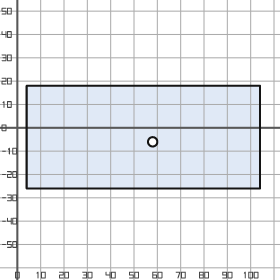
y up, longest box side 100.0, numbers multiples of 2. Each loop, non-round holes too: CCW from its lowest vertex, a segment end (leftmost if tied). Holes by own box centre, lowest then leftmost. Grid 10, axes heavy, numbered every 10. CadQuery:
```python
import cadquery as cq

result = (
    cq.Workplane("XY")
    .moveTo(4.0, -26.0)
    .lineTo(104.0, -26.0)
    .lineTo(104.0, 18.0)
    .lineTo(4.0, 18.0)
    .close()
    .moveTo(58.0, -6.0)
    .circle(2.0)
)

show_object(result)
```